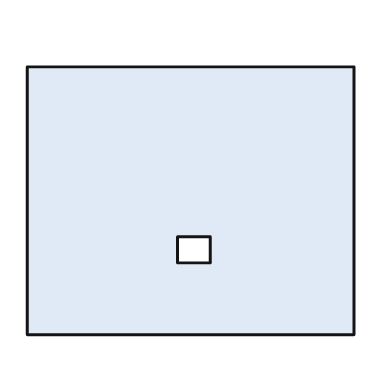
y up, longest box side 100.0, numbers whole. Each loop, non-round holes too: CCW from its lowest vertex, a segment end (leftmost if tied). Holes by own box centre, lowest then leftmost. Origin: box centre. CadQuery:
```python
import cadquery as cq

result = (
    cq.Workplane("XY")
    .moveTo(-50.0, -41.0)
    .lineTo(50.0, -41.0)
    .lineTo(50.0, 41.0)
    .lineTo(-50.0, 41.0)
    .close()
    .moveTo(-4.0, -19.0)
    .lineTo(6.0, -19.0)
    .lineTo(6.0, -11.0)
    .lineTo(-4.0, -11.0)
    .close()
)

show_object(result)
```